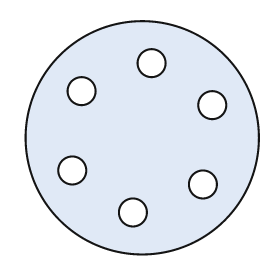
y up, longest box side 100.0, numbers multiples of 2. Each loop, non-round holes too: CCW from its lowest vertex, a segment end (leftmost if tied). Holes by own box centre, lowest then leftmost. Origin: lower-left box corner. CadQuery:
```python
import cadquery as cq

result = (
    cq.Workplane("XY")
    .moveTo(50.0, 50.0)
    .circle(50.0)
    .moveTo(46.0, 18.0)
    .circle(6.0)
    .moveTo(76.0, 30.0)
    .circle(6.0)
    .moveTo(20.0, 36.0)
    .circle(6.0)
    .moveTo(80.0, 64.0)
    .circle(6.0)
    .moveTo(24.0, 70.0)
    .circle(6.0)
    .moveTo(54.0, 82.0)
    .circle(6.0)
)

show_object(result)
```